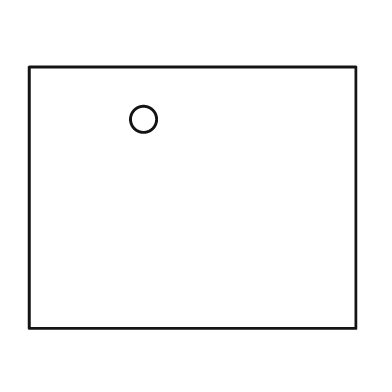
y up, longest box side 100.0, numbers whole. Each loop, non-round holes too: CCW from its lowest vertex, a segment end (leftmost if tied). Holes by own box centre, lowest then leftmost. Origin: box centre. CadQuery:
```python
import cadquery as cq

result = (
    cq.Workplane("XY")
    .moveTo(-50.0, -40.0)
    .lineTo(50.0, -40.0)
    .lineTo(50.0, 40.0)
    .lineTo(-50.0, 40.0)
    .close()
    .moveTo(-15.0, 24.0)
    .circle(4.0)
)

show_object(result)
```